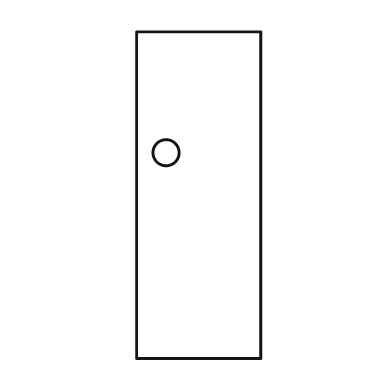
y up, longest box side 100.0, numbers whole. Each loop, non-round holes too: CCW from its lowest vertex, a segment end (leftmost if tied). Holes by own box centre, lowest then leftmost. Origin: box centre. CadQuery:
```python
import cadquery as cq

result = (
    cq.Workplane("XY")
    .moveTo(-19.0, -50.0)
    .lineTo(19.0, -50.0)
    .lineTo(19.0, 50.0)
    .lineTo(-19.0, 50.0)
    .close()
    .moveTo(-10.0, 13.0)
    .circle(4.0)
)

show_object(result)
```